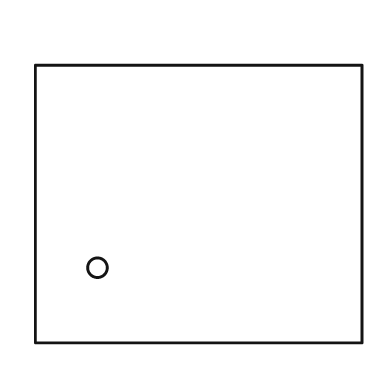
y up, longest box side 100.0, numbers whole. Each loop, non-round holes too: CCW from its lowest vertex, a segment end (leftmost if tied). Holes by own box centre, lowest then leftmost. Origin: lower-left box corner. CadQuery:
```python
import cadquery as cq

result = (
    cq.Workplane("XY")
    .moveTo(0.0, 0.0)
    .lineTo(100.0, 0.0)
    .lineTo(100.0, 85.0)
    .lineTo(0.0, 85.0)
    .close()
    .moveTo(19.0, 23.0)
    .circle(3.0)
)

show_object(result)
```